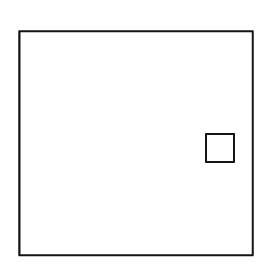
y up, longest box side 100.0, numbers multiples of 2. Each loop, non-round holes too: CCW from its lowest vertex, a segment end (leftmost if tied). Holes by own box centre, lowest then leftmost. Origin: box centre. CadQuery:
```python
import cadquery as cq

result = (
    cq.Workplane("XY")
    .moveTo(-50.0, -48.0)
    .lineTo(50.0, -48.0)
    .lineTo(50.0, 48.0)
    .lineTo(-50.0, 48.0)
    .close()
    .moveTo(30.0, -8.0)
    .lineTo(42.0, -8.0)
    .lineTo(42.0, 4.0)
    .lineTo(30.0, 4.0)
    .close()
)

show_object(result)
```